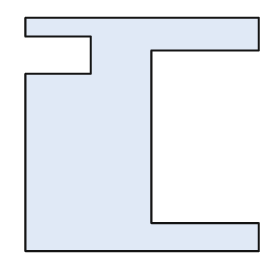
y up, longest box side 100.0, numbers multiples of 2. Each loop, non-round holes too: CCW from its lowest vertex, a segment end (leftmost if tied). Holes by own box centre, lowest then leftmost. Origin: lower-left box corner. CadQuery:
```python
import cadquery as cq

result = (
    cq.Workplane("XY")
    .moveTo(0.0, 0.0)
    .lineTo(100.0, 0.0)
    .lineTo(100.0, 12.0)
    .lineTo(54.0, 12.0)
    .lineTo(54.0, 86.0)
    .lineTo(100.0, 86.0)
    .lineTo(100.0, 100.0)
    .lineTo(0.0, 100.0)
    .lineTo(0.0, 92.0)
    .lineTo(28.0, 92.0)
    .lineTo(28.0, 76.0)
    .lineTo(0.0, 76.0)
    .close()
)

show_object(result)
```